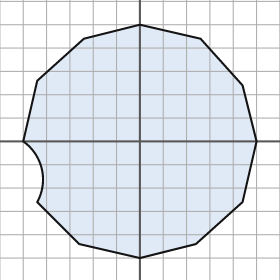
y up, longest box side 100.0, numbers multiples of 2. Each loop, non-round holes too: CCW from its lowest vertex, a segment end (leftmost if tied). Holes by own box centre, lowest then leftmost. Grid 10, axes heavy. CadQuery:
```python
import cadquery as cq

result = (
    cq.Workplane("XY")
    .moveTo(0.0, -50.0)
    .lineTo(24.0, -44.0)
    .lineTo(44.0, -26.0)
    .lineTo(50.0, 0.0)
    .lineTo(44.0, 24.0)
    .lineTo(26.0, 44.0)
    .lineTo(0.0, 50.0)
    .lineTo(-24.0, 44.0)
    .lineTo(-44.0, 26.0)
    .lineTo(-50.0, 0.0)
    .threePointArc((-42.0, -12.0), (-44.0, -26.0))
    .lineTo(-26.0, -44.0)
    .close()
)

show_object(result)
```